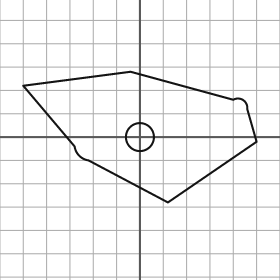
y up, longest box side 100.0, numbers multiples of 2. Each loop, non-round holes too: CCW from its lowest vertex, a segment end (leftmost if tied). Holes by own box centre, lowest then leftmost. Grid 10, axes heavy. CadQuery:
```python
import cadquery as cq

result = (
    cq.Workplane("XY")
    .moveTo(12.0, -28.0)
    .lineTo(50.0, -2.0)
    .lineTo(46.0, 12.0)
    .threePointArc((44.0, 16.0), (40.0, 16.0))
    .lineTo(-4.0, 28.0)
    .lineTo(-50.0, 22.0)
    .lineTo(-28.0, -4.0)
    .threePointArc((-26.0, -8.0), (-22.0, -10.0))
    .close()
    .moveTo(0.0, 0.0)
    .circle(6.0)
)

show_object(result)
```